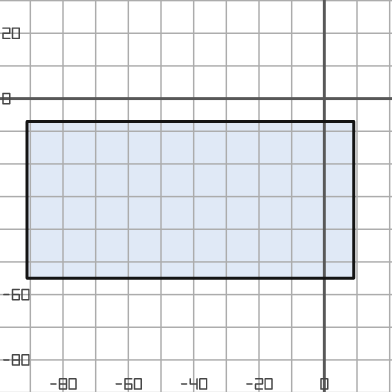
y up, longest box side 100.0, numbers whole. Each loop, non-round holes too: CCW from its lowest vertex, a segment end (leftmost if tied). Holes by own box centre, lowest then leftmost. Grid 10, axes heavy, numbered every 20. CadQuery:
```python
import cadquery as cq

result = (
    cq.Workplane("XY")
    .moveTo(-91.0, -55.0)
    .lineTo(9.0, -55.0)
    .lineTo(9.0, -7.0)
    .lineTo(-91.0, -7.0)
    .close()
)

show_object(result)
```